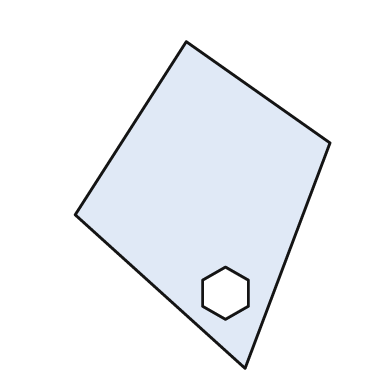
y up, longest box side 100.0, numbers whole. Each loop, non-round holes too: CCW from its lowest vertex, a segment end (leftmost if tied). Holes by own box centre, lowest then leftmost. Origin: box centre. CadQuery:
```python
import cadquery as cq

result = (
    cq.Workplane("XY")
    .moveTo(13.0, -50.0)
    .lineTo(39.0, 19.0)
    .lineTo(-5.0, 50.0)
    .lineTo(-39.0, -3.0)
    .close()
    .moveTo(7.0, -35.0)
    .lineTo(14.0, -31.0)
    .lineTo(14.0, -23.0)
    .lineTo(7.0, -19.0)
    .lineTo(0.0, -23.0)
    .lineTo(0.0, -31.0)
    .close()
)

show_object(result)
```